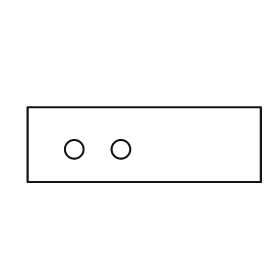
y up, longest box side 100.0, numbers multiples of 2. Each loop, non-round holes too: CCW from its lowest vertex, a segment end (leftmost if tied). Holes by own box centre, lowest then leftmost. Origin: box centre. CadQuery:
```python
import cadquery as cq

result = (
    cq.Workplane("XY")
    .moveTo(-50.0, -16.0)
    .lineTo(50.0, -16.0)
    .lineTo(50.0, 16.0)
    .lineTo(-50.0, 16.0)
    .close()
    .moveTo(-30.0, -2.0)
    .circle(4.0)
    .moveTo(-10.0, -2.0)
    .circle(4.0)
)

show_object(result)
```